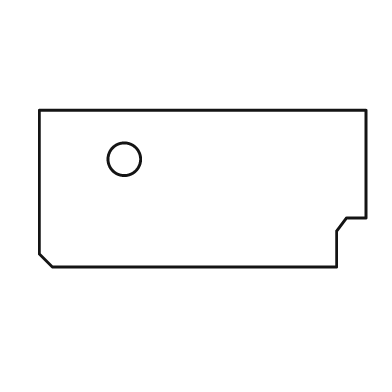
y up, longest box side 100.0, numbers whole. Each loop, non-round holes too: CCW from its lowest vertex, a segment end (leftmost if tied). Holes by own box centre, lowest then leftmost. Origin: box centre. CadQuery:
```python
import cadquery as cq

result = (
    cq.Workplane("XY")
    .moveTo(-46.0, -24.0)
    .lineTo(41.0, -24.0)
    .lineTo(41.0, -13.0)
    .lineTo(44.0, -9.0)
    .lineTo(50.0, -9.0)
    .lineTo(50.0, 24.0)
    .lineTo(-50.0, 24.0)
    .lineTo(-50.0, -20.0)
    .close()
    .moveTo(-24.0, 9.0)
    .circle(5.0)
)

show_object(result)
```